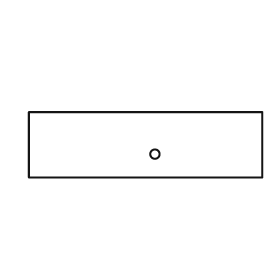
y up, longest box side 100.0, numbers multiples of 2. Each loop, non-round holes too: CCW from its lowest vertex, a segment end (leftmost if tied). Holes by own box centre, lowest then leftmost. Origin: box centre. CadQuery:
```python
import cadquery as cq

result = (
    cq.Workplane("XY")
    .moveTo(-50.0, -14.0)
    .lineTo(50.0, -14.0)
    .lineTo(50.0, 14.0)
    .lineTo(-50.0, 14.0)
    .close()
    .moveTo(4.0, -4.0)
    .circle(2.0)
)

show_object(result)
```